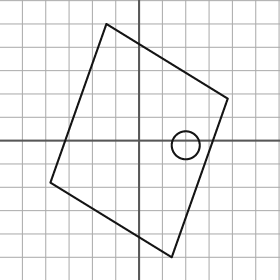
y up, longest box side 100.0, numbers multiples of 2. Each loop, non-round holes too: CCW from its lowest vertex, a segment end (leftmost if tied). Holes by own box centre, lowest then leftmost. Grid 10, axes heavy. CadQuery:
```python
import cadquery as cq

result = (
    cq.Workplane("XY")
    .moveTo(14.0, -50.0)
    .lineTo(38.0, 18.0)
    .lineTo(-14.0, 50.0)
    .lineTo(-38.0, -18.0)
    .close()
    .moveTo(20.0, -2.0)
    .circle(6.0)
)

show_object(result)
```